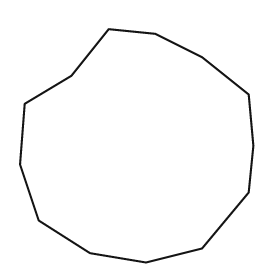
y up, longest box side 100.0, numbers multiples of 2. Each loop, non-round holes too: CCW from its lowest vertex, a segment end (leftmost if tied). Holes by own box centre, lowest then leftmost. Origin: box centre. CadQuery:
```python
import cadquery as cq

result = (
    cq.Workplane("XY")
    .moveTo(4.0, -50.0)
    .lineTo(28.0, -44.0)
    .lineTo(48.0, -20.0)
    .lineTo(50.0, 0.0)
    .lineTo(48.0, 22.0)
    .lineTo(28.0, 38.0)
    .lineTo(8.0, 48.0)
    .lineTo(-12.0, 50.0)
    .lineTo(-28.0, 30.0)
    .lineTo(-48.0, 18.0)
    .lineTo(-50.0, -8.0)
    .lineTo(-42.0, -32.0)
    .lineTo(-20.0, -46.0)
    .close()
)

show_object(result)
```